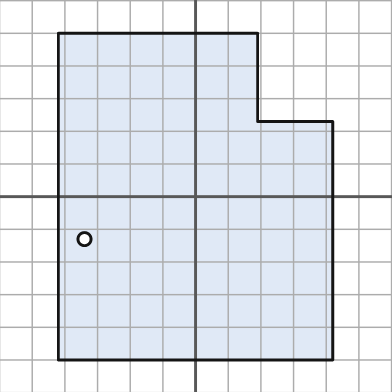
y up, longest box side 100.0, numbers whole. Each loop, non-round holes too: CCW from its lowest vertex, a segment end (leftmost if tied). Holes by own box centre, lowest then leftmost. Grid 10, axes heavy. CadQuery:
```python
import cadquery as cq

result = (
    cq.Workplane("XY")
    .moveTo(-42.0, -50.0)
    .lineTo(42.0, -50.0)
    .lineTo(42.0, 23.0)
    .lineTo(19.0, 23.0)
    .lineTo(19.0, 50.0)
    .lineTo(-42.0, 50.0)
    .close()
    .moveTo(-34.0, -13.0)
    .circle(2.0)
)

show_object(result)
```